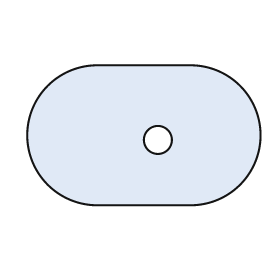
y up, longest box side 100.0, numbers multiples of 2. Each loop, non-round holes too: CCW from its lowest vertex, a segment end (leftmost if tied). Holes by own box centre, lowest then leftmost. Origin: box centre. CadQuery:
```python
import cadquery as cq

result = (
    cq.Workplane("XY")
    .moveTo(-20.0, -30.0)
    .lineTo(20.0, -30.0)
    .threePointArc((50.0, 0.0), (20.0, 30.0))
    .lineTo(-20.0, 30.0)
    .threePointArc((-50.0, 0.0), (-20.0, -30.0))
    .close()
    .moveTo(6.0, -2.0)
    .circle(6.0)
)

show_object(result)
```